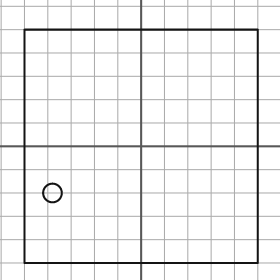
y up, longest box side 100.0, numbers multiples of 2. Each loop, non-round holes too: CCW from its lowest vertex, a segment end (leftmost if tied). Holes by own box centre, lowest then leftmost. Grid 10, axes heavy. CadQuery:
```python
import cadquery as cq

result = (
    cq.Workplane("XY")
    .moveTo(-50.0, -50.0)
    .lineTo(50.0, -50.0)
    .lineTo(50.0, 50.0)
    .lineTo(-50.0, 50.0)
    .close()
    .moveTo(-38.0, -20.0)
    .circle(4.0)
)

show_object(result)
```